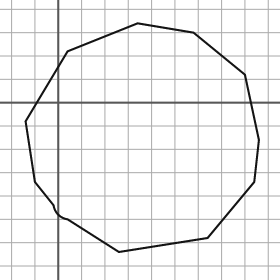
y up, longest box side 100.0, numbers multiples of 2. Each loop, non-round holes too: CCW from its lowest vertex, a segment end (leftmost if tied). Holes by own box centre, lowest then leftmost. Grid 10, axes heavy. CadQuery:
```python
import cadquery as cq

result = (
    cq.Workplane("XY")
    .moveTo(26.0, -64.0)
    .lineTo(64.0, -58.0)
    .lineTo(84.0, -34.0)
    .lineTo(86.0, -16.0)
    .lineTo(80.0, 12.0)
    .lineTo(58.0, 30.0)
    .lineTo(34.0, 34.0)
    .lineTo(4.0, 22.0)
    .lineTo(-14.0, -8.0)
    .lineTo(-10.0, -34.0)
    .lineTo(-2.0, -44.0)
    .threePointArc((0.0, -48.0), (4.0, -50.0))
    .close()
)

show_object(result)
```